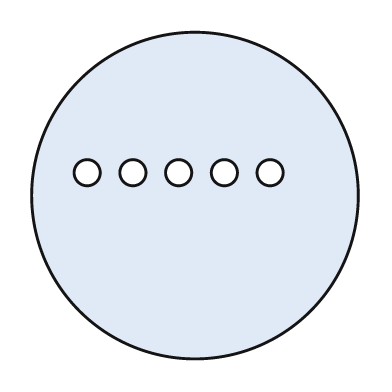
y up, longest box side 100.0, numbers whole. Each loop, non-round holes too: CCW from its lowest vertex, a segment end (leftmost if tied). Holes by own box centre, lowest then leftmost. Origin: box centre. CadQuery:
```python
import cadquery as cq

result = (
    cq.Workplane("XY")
    .moveTo(0.0, 0.0)
    .circle(50.0)
    .moveTo(-33.0, 7.0)
    .circle(4.0)
    .moveTo(-19.0, 7.0)
    .circle(4.0)
    .moveTo(-5.0, 7.0)
    .circle(4.0)
    .moveTo(9.0, 7.0)
    .circle(4.0)
    .moveTo(23.0, 7.0)
    .circle(4.0)
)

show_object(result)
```